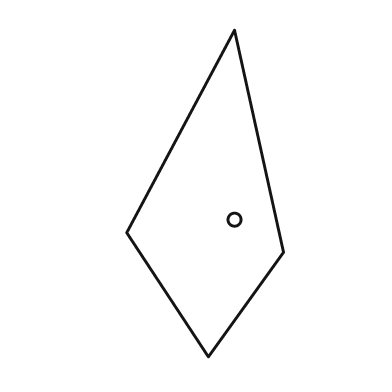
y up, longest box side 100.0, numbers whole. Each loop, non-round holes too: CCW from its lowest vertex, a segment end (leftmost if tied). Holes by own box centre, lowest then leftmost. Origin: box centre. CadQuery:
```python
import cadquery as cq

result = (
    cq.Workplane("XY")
    .moveTo(1.0, -50.0)
    .lineTo(24.0, -18.0)
    .lineTo(9.0, 50.0)
    .lineTo(-24.0, -12.0)
    .close()
    .moveTo(9.0, -8.0)
    .circle(2.0)
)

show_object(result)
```